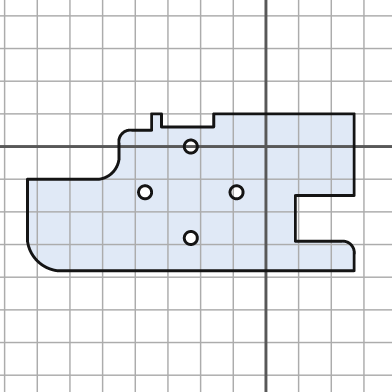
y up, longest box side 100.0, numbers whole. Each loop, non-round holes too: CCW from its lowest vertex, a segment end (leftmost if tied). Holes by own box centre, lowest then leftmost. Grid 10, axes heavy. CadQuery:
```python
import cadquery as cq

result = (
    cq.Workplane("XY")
    .moveTo(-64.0, -38.0)
    .lineTo(27.0, -38.0)
    .lineTo(27.0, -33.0)
    .threePointArc((26.0, -30.0), (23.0, -29.0))
    .lineTo(9.0, -29.0)
    .lineTo(9.0, -15.0)
    .lineTo(27.0, -15.0)
    .lineTo(27.0, 10.0)
    .lineTo(-16.0, 10.0)
    .lineTo(-16.0, 6.0)
    .lineTo(-32.0, 6.0)
    .lineTo(-32.0, 10.0)
    .lineTo(-35.0, 10.0)
    .lineTo(-35.0, 5.0)
    .lineTo(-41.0, 5.0)
    .threePointArc((-44.0, 4.0), (-45.0, 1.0))
    .lineTo(-45.0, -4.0)
    .threePointArc((-47.0, -8.0), (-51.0, -10.0))
    .lineTo(-73.0, -10.0)
    .lineTo(-73.0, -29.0)
    .threePointArc((-70.0, -35.0), (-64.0, -38.0))
    .close()
    .moveTo(-23.0, -28.0)
    .circle(2.0)
    .moveTo(-37.0, -14.0)
    .circle(2.0)
    .moveTo(-9.0, -14.0)
    .circle(2.0)
    .moveTo(-23.0, 0.0)
    .circle(2.0)
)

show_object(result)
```